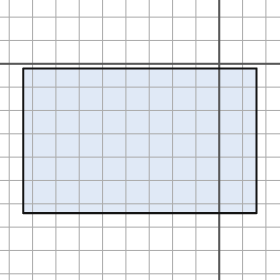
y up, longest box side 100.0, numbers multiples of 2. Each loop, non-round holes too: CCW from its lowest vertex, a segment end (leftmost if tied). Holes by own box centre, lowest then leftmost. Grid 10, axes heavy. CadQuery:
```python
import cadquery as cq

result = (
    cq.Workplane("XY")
    .moveTo(-84.0, -64.0)
    .lineTo(16.0, -64.0)
    .lineTo(16.0, -2.0)
    .lineTo(-84.0, -2.0)
    .close()
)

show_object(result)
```